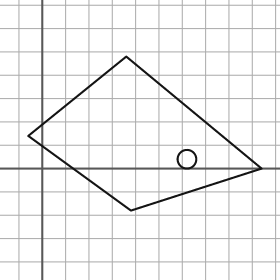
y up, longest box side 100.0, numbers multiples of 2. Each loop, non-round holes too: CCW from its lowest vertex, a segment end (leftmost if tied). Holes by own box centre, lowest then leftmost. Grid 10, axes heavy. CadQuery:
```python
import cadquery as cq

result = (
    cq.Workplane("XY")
    .moveTo(38.0, -18.0)
    .lineTo(94.0, 0.0)
    .lineTo(36.0, 48.0)
    .lineTo(-6.0, 14.0)
    .close()
    .moveTo(62.0, 4.0)
    .circle(4.0)
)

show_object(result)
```